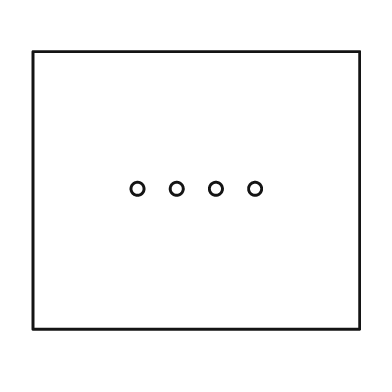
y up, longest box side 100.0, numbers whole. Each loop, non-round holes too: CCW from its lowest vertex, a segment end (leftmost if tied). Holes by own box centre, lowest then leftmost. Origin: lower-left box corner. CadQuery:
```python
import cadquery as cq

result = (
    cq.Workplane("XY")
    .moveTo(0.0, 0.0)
    .lineTo(100.0, 0.0)
    .lineTo(100.0, 85.0)
    .lineTo(0.0, 85.0)
    .close()
    .moveTo(32.0, 43.0)
    .circle(2.0)
    .moveTo(44.0, 43.0)
    .circle(2.0)
    .moveTo(56.0, 43.0)
    .circle(2.0)
    .moveTo(68.0, 43.0)
    .circle(2.0)
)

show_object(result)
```